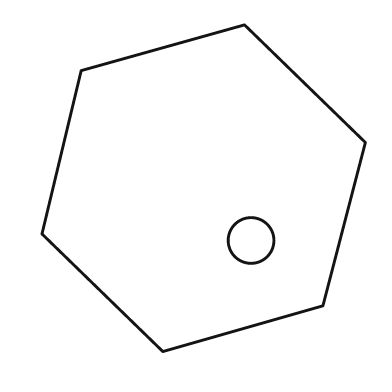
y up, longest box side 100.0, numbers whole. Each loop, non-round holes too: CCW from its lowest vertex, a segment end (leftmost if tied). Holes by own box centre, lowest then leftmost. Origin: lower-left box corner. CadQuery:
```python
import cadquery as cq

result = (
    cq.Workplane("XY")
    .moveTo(37.0, 0.0)
    .lineTo(86.0, 14.0)
    .lineTo(99.0, 64.0)
    .lineTo(62.0, 100.0)
    .lineTo(12.0, 86.0)
    .lineTo(0.0, 36.0)
    .close()
    .moveTo(64.0, 34.0)
    .circle(7.0)
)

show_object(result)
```